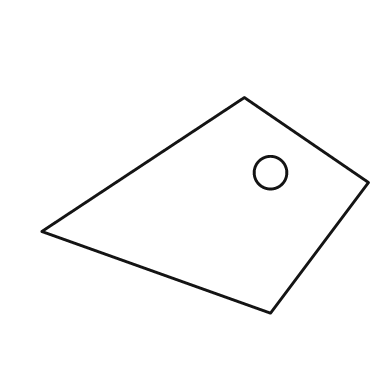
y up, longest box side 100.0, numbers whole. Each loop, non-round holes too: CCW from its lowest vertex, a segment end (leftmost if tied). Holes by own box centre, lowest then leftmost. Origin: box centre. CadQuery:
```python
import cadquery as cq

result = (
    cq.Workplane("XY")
    .moveTo(20.0, -33.0)
    .lineTo(50.0, 7.0)
    .lineTo(12.0, 33.0)
    .lineTo(-50.0, -8.0)
    .close()
    .moveTo(20.0, 10.0)
    .circle(5.0)
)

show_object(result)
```